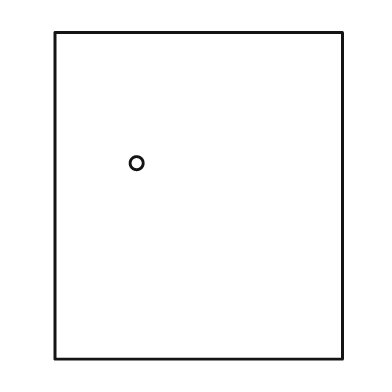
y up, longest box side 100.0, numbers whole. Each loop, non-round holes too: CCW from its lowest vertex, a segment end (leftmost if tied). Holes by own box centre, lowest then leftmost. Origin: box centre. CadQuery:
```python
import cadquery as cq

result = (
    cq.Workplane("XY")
    .moveTo(-44.0, -50.0)
    .lineTo(44.0, -50.0)
    .lineTo(44.0, 50.0)
    .lineTo(-44.0, 50.0)
    .close()
    .moveTo(-19.0, 10.0)
    .circle(2.0)
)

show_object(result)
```